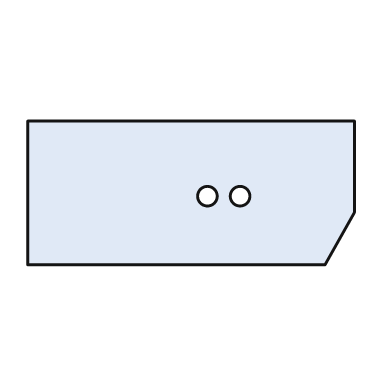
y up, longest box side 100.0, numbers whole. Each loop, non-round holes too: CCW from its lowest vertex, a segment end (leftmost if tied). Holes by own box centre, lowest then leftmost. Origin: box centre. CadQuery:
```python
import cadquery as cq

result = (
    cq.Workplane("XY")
    .moveTo(-50.0, -22.0)
    .lineTo(41.0, -22.0)
    .lineTo(50.0, -6.0)
    .lineTo(50.0, 22.0)
    .lineTo(-50.0, 22.0)
    .close()
    .moveTo(5.0, -1.0)
    .circle(3.0)
    .moveTo(15.0, -1.0)
    .circle(3.0)
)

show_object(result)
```